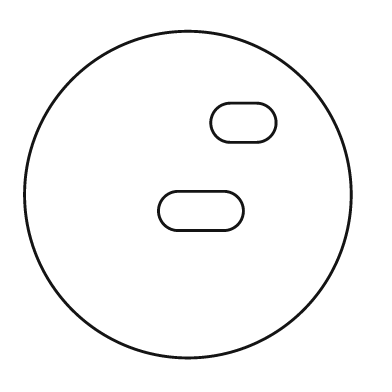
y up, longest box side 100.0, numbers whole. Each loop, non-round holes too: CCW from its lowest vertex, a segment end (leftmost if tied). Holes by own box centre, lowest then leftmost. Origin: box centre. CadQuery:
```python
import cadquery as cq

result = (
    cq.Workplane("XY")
    .moveTo(0.0, 0.0)
    .circle(50.0)
    .moveTo(-3.0, -11.0)
    .lineTo(11.0, -11.0)
    .threePointArc((17.0, -5.0), (11.0, 1.0))
    .lineTo(-3.0, 1.0)
    .threePointArc((-9.0, -5.0), (-3.0, -11.0))
    .close()
    .moveTo(13.0, 16.0)
    .lineTo(21.0, 16.0)
    .threePointArc((27.0, 22.0), (21.0, 28.0))
    .lineTo(13.0, 28.0)
    .threePointArc((7.0, 22.0), (13.0, 16.0))
    .close()
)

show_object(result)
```